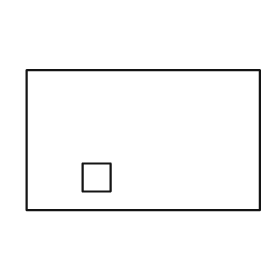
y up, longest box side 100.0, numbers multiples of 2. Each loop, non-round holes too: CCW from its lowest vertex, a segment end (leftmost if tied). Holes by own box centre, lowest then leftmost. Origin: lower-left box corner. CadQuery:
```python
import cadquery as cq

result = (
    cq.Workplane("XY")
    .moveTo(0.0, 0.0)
    .lineTo(100.0, 0.0)
    .lineTo(100.0, 60.0)
    .lineTo(0.0, 60.0)
    .close()
    .moveTo(24.0, 8.0)
    .lineTo(36.0, 8.0)
    .lineTo(36.0, 20.0)
    .lineTo(24.0, 20.0)
    .close()
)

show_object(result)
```